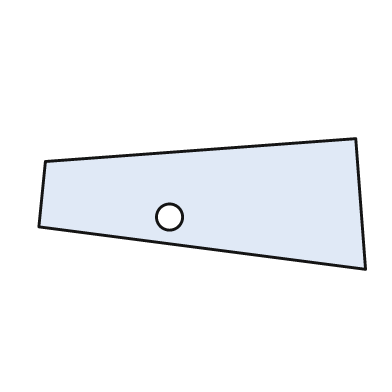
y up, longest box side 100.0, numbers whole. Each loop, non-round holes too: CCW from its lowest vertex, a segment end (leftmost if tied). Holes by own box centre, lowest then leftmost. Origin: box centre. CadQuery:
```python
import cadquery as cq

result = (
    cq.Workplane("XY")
    .moveTo(50.0, -20.0)
    .lineTo(47.0, 20.0)
    .lineTo(-48.0, 13.0)
    .lineTo(-50.0, -7.0)
    .close()
    .moveTo(-10.0, -4.0)
    .circle(4.0)
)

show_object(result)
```